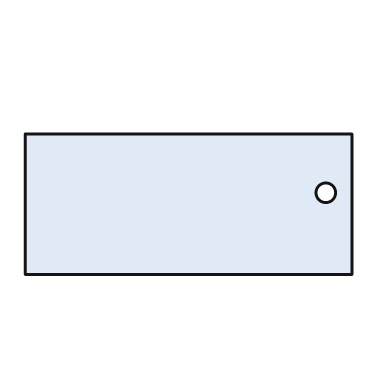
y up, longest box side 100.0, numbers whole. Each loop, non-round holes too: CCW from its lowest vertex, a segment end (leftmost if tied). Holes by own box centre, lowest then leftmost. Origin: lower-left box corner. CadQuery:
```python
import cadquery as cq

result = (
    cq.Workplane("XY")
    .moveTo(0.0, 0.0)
    .lineTo(100.0, 0.0)
    .lineTo(100.0, 43.0)
    .lineTo(0.0, 43.0)
    .close()
    .moveTo(92.0, 25.0)
    .circle(3.0)
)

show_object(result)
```